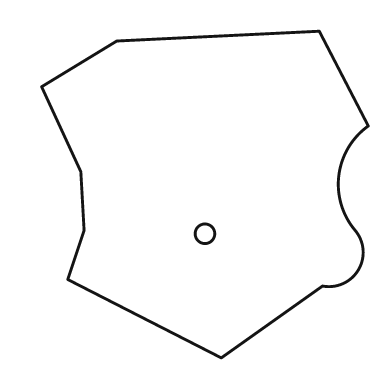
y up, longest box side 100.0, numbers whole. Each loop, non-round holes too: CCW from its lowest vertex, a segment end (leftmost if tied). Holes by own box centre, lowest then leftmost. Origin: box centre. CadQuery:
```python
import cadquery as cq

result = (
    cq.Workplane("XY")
    .moveTo(5.0, -50.0)
    .lineTo(36.0, -28.0)
    .threePointArc((47.0, -23.0), (46.0, -11.0))
    .threePointArc((41.0, 6.0), (50.0, 21.0))
    .lineTo(35.0, 50.0)
    .lineTo(-27.0, 47.0)
    .lineTo(-50.0, 33.0)
    .lineTo(-38.0, 7.0)
    .lineTo(-37.0, -11.0)
    .lineTo(-42.0, -26.0)
    .close()
    .moveTo(0.0, -12.0)
    .circle(3.0)
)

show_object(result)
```